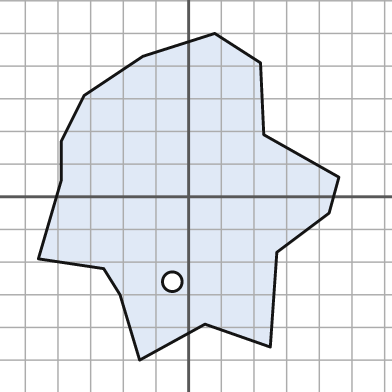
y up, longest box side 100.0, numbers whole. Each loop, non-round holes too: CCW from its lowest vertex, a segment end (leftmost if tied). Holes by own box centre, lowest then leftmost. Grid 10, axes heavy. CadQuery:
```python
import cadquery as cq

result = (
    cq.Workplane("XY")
    .moveTo(-15.0, -50.0)
    .lineTo(5.0, -39.0)
    .lineTo(25.0, -46.0)
    .lineTo(27.0, -17.0)
    .lineTo(43.0, -5.0)
    .lineTo(46.0, 6.0)
    .lineTo(23.0, 19.0)
    .lineTo(22.0, 41.0)
    .lineTo(8.0, 50.0)
    .lineTo(-14.0, 43.0)
    .lineTo(-32.0, 31.0)
    .lineTo(-39.0, 17.0)
    .lineTo(-39.0, 5.0)
    .lineTo(-46.0, -19.0)
    .lineTo(-26.0, -22.0)
    .lineTo(-21.0, -30.0)
    .close()
    .moveTo(-5.0, -26.0)
    .circle(3.0)
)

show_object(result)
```